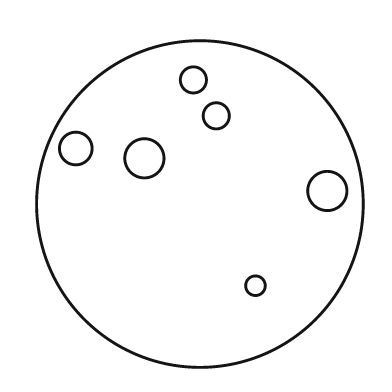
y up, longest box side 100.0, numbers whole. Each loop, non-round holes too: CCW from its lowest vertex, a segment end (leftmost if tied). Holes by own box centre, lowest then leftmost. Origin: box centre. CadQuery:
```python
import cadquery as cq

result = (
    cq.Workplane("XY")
    .moveTo(0.0, 0.0)
    .circle(50.0)
    .moveTo(17.0, -25.0)
    .circle(3.0)
    .moveTo(39.0, 4.0)
    .circle(6.0)
    .moveTo(-17.0, 14.0)
    .circle(6.0)
    .moveTo(-38.0, 17.0)
    .circle(5.0)
    .moveTo(5.0, 27.0)
    .circle(4.0)
    .moveTo(-2.0, 38.0)
    .circle(4.0)
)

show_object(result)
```